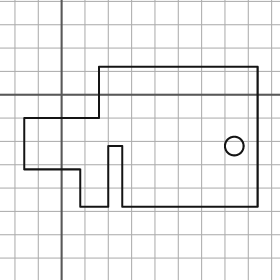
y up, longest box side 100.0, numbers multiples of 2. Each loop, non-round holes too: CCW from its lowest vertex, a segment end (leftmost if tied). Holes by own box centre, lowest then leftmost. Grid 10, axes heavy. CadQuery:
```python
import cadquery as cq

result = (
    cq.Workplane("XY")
    .moveTo(8.0, -48.0)
    .lineTo(20.0, -48.0)
    .lineTo(20.0, -22.0)
    .lineTo(26.0, -22.0)
    .lineTo(26.0, -48.0)
    .lineTo(84.0, -48.0)
    .lineTo(84.0, 12.0)
    .lineTo(16.0, 12.0)
    .lineTo(16.0, -10.0)
    .lineTo(-16.0, -10.0)
    .lineTo(-16.0, -32.0)
    .lineTo(8.0, -32.0)
    .close()
    .moveTo(74.0, -22.0)
    .circle(4.0)
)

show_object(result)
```